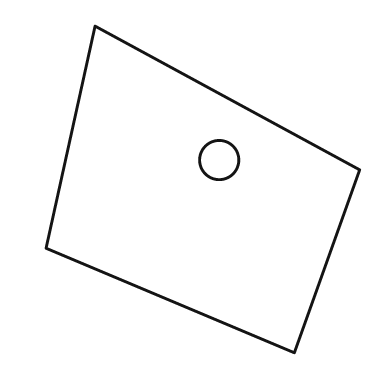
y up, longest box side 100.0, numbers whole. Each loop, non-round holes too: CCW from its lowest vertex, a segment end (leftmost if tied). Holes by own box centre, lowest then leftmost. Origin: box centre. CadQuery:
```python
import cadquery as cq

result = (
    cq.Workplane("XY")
    .moveTo(28.0, -50.0)
    .lineTo(48.0, 6.0)
    .lineTo(-33.0, 50.0)
    .lineTo(-48.0, -18.0)
    .close()
    .moveTo(5.0, 9.0)
    .circle(6.0)
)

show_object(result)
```